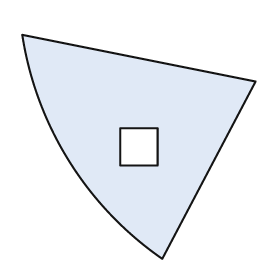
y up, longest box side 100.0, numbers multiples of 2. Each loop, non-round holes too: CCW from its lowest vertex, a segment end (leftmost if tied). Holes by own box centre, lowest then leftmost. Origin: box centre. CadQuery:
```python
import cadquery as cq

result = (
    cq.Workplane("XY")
    .moveTo(10.0, -48.0)
    .lineTo(50.0, 28.0)
    .lineTo(-50.0, 48.0)
    .threePointArc((-30.0, -6.0), (10.0, -48.0))
    .close()
    .moveTo(-8.0, -8.0)
    .lineTo(8.0, -8.0)
    .lineTo(8.0, 8.0)
    .lineTo(-8.0, 8.0)
    .close()
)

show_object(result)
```